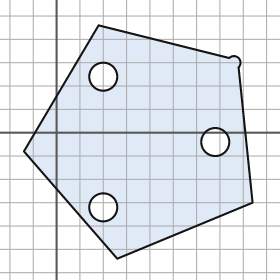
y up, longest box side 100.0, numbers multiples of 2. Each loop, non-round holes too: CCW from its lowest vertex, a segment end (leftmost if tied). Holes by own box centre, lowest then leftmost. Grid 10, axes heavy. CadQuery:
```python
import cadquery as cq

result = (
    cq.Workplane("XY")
    .moveTo(26.0, -54.0)
    .lineTo(84.0, -30.0)
    .lineTo(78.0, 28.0)
    .threePointArc((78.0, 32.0), (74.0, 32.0))
    .lineTo(18.0, 46.0)
    .lineTo(-14.0, -8.0)
    .close()
    .moveTo(20.0, -32.0)
    .circle(6.0)
    .moveTo(68.0, -4.0)
    .circle(6.0)
    .moveTo(20.0, 24.0)
    .circle(6.0)
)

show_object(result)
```